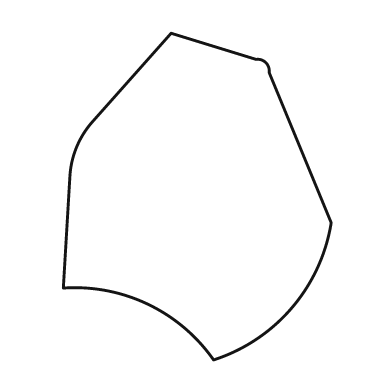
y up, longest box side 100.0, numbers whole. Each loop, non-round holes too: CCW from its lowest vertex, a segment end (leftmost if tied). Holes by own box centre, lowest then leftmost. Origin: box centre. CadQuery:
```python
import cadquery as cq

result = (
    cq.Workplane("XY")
    .moveTo(5.0, -50.0)
    .threePointArc((29.0, -34.0), (41.0, -8.0))
    .lineTo(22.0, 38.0)
    .threePointArc((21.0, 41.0), (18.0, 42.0))
    .lineTo(-8.0, 50.0)
    .lineTo(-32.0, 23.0)
    .threePointArc((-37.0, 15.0), (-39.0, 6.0))
    .lineTo(-41.0, -28.0)
    .threePointArc((-15.0, -33.0), (5.0, -50.0))
    .close()
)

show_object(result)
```